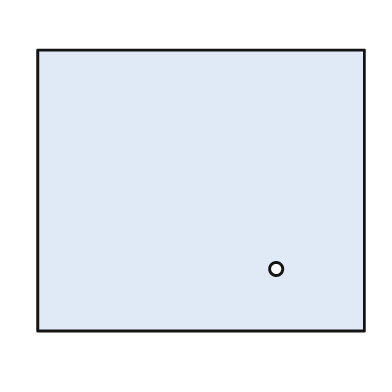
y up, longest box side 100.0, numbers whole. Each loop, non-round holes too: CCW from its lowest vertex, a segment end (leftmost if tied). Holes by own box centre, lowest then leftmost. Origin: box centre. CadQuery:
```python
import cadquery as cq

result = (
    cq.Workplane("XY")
    .moveTo(-50.0, -43.0)
    .lineTo(50.0, -43.0)
    .lineTo(50.0, 43.0)
    .lineTo(-50.0, 43.0)
    .close()
    .moveTo(23.0, -24.0)
    .circle(2.0)
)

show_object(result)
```